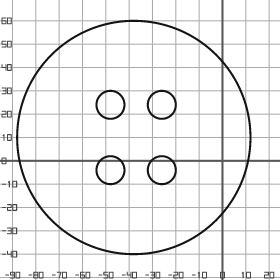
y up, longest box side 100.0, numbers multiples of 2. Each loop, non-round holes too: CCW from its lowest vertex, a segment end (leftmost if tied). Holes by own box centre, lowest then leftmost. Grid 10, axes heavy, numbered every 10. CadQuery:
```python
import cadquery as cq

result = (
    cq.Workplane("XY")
    .moveTo(-38.0, 10.0)
    .circle(50.0)
    .moveTo(-48.0, -4.0)
    .circle(6.0)
    .moveTo(-26.0, -4.0)
    .circle(6.0)
    .moveTo(-48.0, 24.0)
    .circle(6.0)
    .moveTo(-26.0, 24.0)
    .circle(6.0)
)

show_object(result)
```